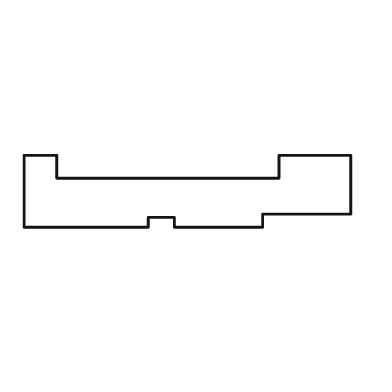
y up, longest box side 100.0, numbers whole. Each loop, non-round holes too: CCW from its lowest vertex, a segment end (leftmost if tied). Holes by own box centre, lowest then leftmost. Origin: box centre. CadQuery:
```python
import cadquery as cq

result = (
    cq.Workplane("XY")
    .moveTo(-50.0, -11.0)
    .lineTo(-12.0, -11.0)
    .lineTo(-12.0, -8.0)
    .lineTo(-4.0, -8.0)
    .lineTo(-4.0, -11.0)
    .lineTo(23.0, -11.0)
    .lineTo(23.0, -7.0)
    .lineTo(50.0, -7.0)
    .lineTo(50.0, 11.0)
    .lineTo(28.0, 11.0)
    .lineTo(28.0, 4.0)
    .lineTo(-40.0, 4.0)
    .lineTo(-40.0, 11.0)
    .lineTo(-50.0, 11.0)
    .close()
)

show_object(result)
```